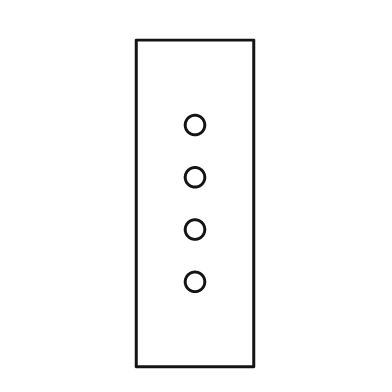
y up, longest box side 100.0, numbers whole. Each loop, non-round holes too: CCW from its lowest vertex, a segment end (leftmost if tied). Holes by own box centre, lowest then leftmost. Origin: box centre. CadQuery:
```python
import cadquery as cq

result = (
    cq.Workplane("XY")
    .moveTo(-18.0, -50.0)
    .lineTo(18.0, -50.0)
    .lineTo(18.0, 50.0)
    .lineTo(-18.0, 50.0)
    .close()
    .moveTo(0.0, -24.0)
    .circle(3.0)
    .moveTo(0.0, -8.0)
    .circle(3.0)
    .moveTo(0.0, 8.0)
    .circle(3.0)
    .moveTo(0.0, 24.0)
    .circle(3.0)
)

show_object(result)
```